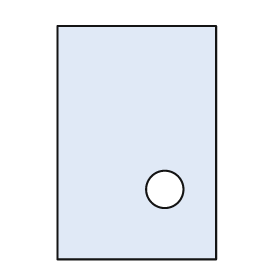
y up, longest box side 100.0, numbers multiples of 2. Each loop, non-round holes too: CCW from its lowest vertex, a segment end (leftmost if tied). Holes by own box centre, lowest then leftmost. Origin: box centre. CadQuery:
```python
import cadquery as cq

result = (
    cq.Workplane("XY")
    .moveTo(-34.0, -50.0)
    .lineTo(34.0, -50.0)
    .lineTo(34.0, 50.0)
    .lineTo(-34.0, 50.0)
    .close()
    .moveTo(12.0, -20.0)
    .circle(8.0)
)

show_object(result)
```